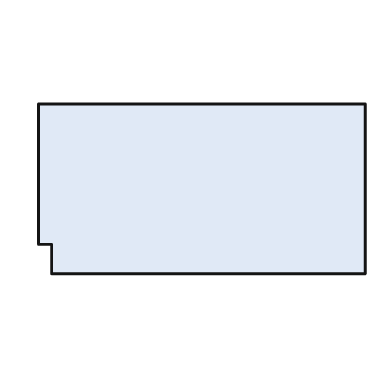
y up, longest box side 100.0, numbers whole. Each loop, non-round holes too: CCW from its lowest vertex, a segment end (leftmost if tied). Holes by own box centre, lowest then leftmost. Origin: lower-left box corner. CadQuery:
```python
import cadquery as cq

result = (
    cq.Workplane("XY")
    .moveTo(4.0, 0.0)
    .lineTo(100.0, 0.0)
    .lineTo(100.0, 52.0)
    .lineTo(0.0, 52.0)
    .lineTo(0.0, 9.0)
    .lineTo(4.0, 9.0)
    .close()
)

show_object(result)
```